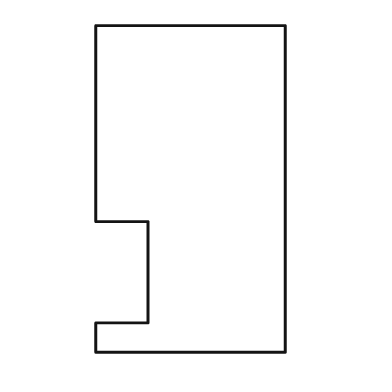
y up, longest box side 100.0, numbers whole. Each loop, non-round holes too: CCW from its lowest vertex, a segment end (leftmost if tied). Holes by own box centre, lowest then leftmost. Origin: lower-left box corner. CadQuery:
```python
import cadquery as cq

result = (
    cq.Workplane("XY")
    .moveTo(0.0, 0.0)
    .lineTo(58.0, 0.0)
    .lineTo(58.0, 100.0)
    .lineTo(0.0, 100.0)
    .lineTo(0.0, 40.0)
    .lineTo(16.0, 40.0)
    .lineTo(16.0, 9.0)
    .lineTo(0.0, 9.0)
    .close()
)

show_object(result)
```